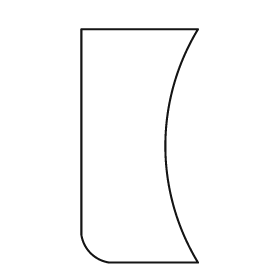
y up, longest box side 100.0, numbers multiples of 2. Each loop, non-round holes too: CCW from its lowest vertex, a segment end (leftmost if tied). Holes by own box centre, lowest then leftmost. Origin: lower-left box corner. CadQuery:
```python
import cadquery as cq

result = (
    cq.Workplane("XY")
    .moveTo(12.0, 0.0)
    .lineTo(50.0, 0.0)
    .threePointArc((36.0, 50.0), (50.0, 100.0))
    .lineTo(0.0, 100.0)
    .lineTo(0.0, 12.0)
    .threePointArc((4.0, 4.0), (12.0, 0.0))
    .close()
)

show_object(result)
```